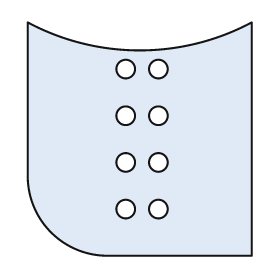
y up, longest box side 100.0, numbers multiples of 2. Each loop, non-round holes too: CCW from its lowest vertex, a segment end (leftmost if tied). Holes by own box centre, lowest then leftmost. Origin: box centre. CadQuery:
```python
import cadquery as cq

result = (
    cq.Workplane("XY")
    .moveTo(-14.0, -50.0)
    .lineTo(48.0, -50.0)
    .lineTo(48.0, 50.0)
    .threePointArc((0.0, 38.0), (-48.0, 50.0))
    .lineTo(-48.0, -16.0)
    .threePointArc((-38.0, -40.0), (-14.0, -50.0))
    .close()
    .moveTo(-6.0, -30.0)
    .circle(4.0)
    .moveTo(8.0, -30.0)
    .circle(4.0)
    .moveTo(-6.0, -10.0)
    .circle(4.0)
    .moveTo(8.0, -10.0)
    .circle(4.0)
    .moveTo(-6.0, 10.0)
    .circle(4.0)
    .moveTo(8.0, 10.0)
    .circle(4.0)
    .moveTo(-6.0, 30.0)
    .circle(4.0)
    .moveTo(8.0, 30.0)
    .circle(4.0)
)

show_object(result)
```